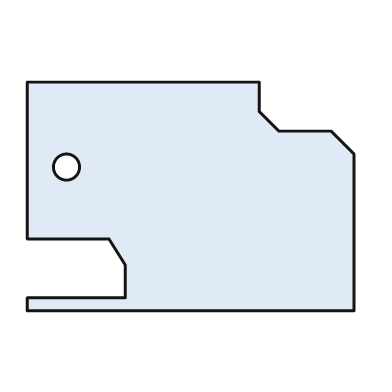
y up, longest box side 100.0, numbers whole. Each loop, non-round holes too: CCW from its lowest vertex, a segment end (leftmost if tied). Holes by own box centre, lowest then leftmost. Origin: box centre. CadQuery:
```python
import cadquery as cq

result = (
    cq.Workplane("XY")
    .moveTo(-50.0, -35.0)
    .lineTo(50.0, -35.0)
    .lineTo(50.0, 13.0)
    .lineTo(43.0, 20.0)
    .lineTo(27.0, 20.0)
    .lineTo(21.0, 26.0)
    .lineTo(21.0, 35.0)
    .lineTo(-50.0, 35.0)
    .lineTo(-50.0, -13.0)
    .lineTo(-25.0, -13.0)
    .lineTo(-20.0, -21.0)
    .lineTo(-20.0, -31.0)
    .lineTo(-50.0, -31.0)
    .close()
    .moveTo(-38.0, 9.0)
    .circle(4.0)
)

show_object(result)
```